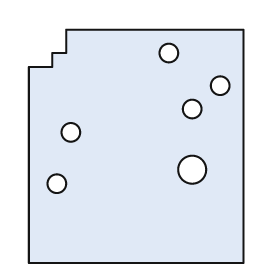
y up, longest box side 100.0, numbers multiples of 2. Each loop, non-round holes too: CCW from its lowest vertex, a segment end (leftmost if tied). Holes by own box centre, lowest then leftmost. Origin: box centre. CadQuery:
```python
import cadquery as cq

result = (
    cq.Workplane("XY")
    .moveTo(-46.0, -50.0)
    .lineTo(46.0, -50.0)
    .lineTo(46.0, 50.0)
    .lineTo(-30.0, 50.0)
    .lineTo(-30.0, 40.0)
    .lineTo(-36.0, 40.0)
    .lineTo(-36.0, 34.0)
    .lineTo(-46.0, 34.0)
    .close()
    .moveTo(-34.0, -16.0)
    .circle(4.0)
    .moveTo(24.0, -10.0)
    .circle(6.0)
    .moveTo(-28.0, 6.0)
    .circle(4.0)
    .moveTo(24.0, 16.0)
    .circle(4.0)
    .moveTo(36.0, 26.0)
    .circle(4.0)
    .moveTo(14.0, 40.0)
    .circle(4.0)
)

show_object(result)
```